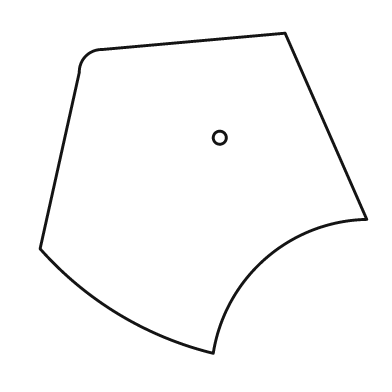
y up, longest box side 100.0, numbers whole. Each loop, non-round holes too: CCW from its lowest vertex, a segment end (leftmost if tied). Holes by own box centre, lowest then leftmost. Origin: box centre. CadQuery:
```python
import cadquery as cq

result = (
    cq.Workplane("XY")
    .moveTo(3.0, -49.0)
    .threePointArc((19.0, -20.0), (50.0, -8.0))
    .lineTo(25.0, 49.0)
    .lineTo(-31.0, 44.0)
    .threePointArc((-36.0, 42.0), (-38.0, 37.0))
    .lineTo(-50.0, -17.0)
    .threePointArc((-26.0, -37.0), (3.0, -49.0))
    .close()
    .moveTo(5.0, 17.0)
    .circle(2.0)
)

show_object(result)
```